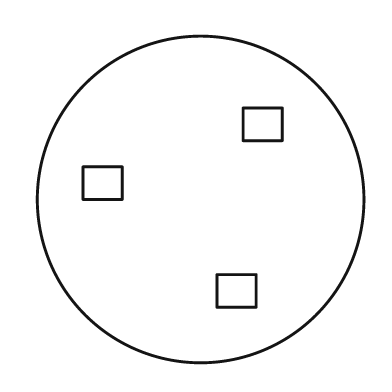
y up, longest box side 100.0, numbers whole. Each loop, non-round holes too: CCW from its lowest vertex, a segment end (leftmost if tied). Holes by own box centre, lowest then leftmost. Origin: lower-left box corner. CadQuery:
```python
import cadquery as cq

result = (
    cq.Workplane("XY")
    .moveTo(50.0, 50.0)
    .circle(50.0)
    .moveTo(55.0, 17.0)
    .lineTo(67.0, 17.0)
    .lineTo(67.0, 27.0)
    .lineTo(55.0, 27.0)
    .close()
    .moveTo(14.0, 50.0)
    .lineTo(26.0, 50.0)
    .lineTo(26.0, 60.0)
    .lineTo(14.0, 60.0)
    .close()
    .moveTo(63.0, 68.0)
    .lineTo(75.0, 68.0)
    .lineTo(75.0, 78.0)
    .lineTo(63.0, 78.0)
    .close()
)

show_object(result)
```